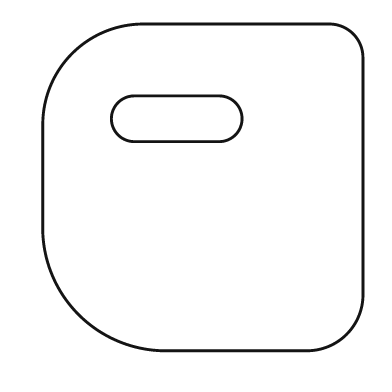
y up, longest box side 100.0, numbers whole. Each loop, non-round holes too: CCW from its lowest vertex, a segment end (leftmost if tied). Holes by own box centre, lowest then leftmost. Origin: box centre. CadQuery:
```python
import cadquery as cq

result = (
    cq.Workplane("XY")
    .moveTo(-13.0, -50.0)
    .lineTo(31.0, -50.0)
    .threePointArc((44.0, -45.0), (49.0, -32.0))
    .lineTo(49.0, 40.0)
    .threePointArc((46.0, 47.0), (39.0, 50.0))
    .lineTo(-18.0, 50.0)
    .threePointArc((-40.0, 41.0), (-49.0, 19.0))
    .lineTo(-49.0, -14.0)
    .threePointArc((-38.0, -39.0), (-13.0, -50.0))
    .close()
    .moveTo(-21.0, 14.0)
    .lineTo(5.0, 14.0)
    .threePointArc((12.0, 21.0), (5.0, 28.0))
    .lineTo(-21.0, 28.0)
    .threePointArc((-28.0, 21.0), (-21.0, 14.0))
    .close()
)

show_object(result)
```